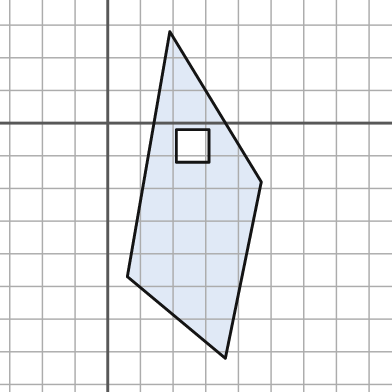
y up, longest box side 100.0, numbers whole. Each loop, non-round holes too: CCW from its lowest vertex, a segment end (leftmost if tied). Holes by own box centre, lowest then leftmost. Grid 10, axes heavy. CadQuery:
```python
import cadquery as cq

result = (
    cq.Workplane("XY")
    .moveTo(36.0, -72.0)
    .lineTo(47.0, -18.0)
    .lineTo(19.0, 28.0)
    .lineTo(6.0, -47.0)
    .close()
    .moveTo(21.0, -12.0)
    .lineTo(31.0, -12.0)
    .lineTo(31.0, -2.0)
    .lineTo(21.0, -2.0)
    .close()
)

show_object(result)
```